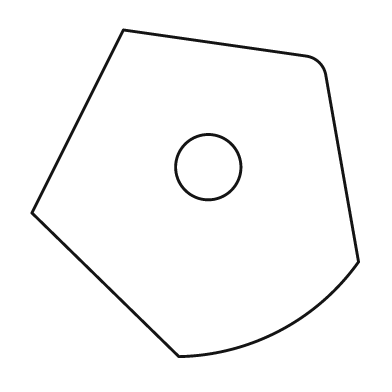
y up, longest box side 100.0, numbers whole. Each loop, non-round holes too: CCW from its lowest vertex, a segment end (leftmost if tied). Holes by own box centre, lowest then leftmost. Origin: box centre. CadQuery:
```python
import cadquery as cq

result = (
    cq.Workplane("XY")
    .moveTo(-5.0, -50.0)
    .threePointArc((26.0, -42.0), (50.0, -21.0))
    .lineTo(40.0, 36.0)
    .threePointArc((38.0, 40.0), (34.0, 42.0))
    .lineTo(-22.0, 50.0)
    .lineTo(-50.0, -6.0)
    .close()
    .moveTo(4.0, 8.0)
    .circle(10.0)
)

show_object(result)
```